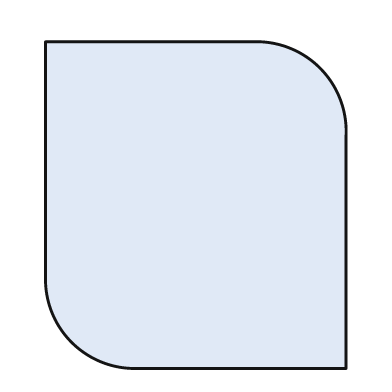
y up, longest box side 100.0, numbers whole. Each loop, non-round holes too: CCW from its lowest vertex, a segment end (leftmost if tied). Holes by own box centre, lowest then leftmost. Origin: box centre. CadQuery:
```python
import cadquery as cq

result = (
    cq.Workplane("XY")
    .moveTo(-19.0, -50.0)
    .lineTo(46.0, -50.0)
    .lineTo(46.0, 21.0)
    .threePointArc((38.0, 42.0), (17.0, 50.0))
    .lineTo(-46.0, 50.0)
    .lineTo(-46.0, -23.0)
    .threePointArc((-38.0, -42.0), (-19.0, -50.0))
    .close()
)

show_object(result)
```